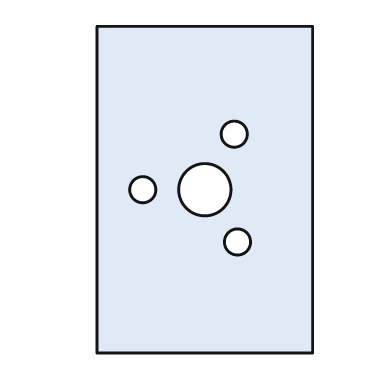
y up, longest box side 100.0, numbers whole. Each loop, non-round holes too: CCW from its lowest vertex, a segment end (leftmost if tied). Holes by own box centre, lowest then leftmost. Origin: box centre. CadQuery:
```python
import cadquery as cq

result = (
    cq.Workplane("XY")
    .moveTo(-33.0, -50.0)
    .lineTo(33.0, -50.0)
    .lineTo(33.0, 50.0)
    .lineTo(-33.0, 50.0)
    .close()
    .moveTo(10.0, -16.0)
    .circle(4.0)
    .moveTo(-19.0, 0.0)
    .circle(4.0)
    .moveTo(0.0, 0.0)
    .circle(8.0)
    .moveTo(9.0, 17.0)
    .circle(4.0)
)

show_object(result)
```